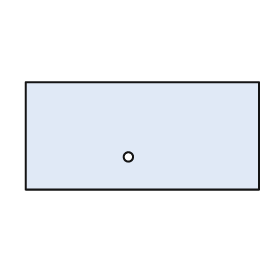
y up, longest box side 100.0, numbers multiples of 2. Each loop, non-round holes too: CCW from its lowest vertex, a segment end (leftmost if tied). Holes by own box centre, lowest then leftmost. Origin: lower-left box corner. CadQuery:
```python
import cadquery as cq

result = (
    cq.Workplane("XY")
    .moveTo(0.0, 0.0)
    .lineTo(100.0, 0.0)
    .lineTo(100.0, 46.0)
    .lineTo(0.0, 46.0)
    .close()
    .moveTo(44.0, 14.0)
    .circle(2.0)
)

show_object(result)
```